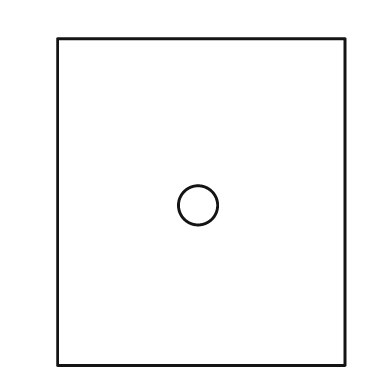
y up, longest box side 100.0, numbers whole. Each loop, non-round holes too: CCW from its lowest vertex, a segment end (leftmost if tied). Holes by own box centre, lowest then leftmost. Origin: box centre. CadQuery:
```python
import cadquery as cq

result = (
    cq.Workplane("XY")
    .moveTo(-44.0, -50.0)
    .lineTo(44.0, -50.0)
    .lineTo(44.0, 50.0)
    .lineTo(-44.0, 50.0)
    .close()
    .moveTo(-1.0, -1.0)
    .circle(6.0)
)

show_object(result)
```